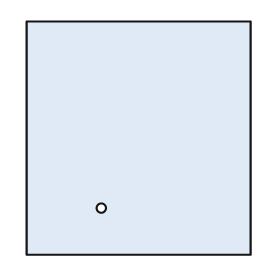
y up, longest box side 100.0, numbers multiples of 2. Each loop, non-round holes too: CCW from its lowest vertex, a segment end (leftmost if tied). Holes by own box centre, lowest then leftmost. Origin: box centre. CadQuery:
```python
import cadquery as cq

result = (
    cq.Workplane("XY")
    .moveTo(-48.0, -50.0)
    .lineTo(48.0, -50.0)
    .lineTo(48.0, 50.0)
    .lineTo(-48.0, 50.0)
    .close()
    .moveTo(-16.0, -30.0)
    .circle(2.0)
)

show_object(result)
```